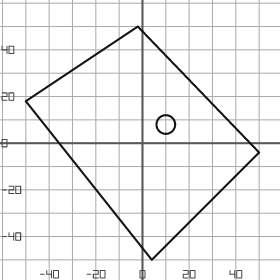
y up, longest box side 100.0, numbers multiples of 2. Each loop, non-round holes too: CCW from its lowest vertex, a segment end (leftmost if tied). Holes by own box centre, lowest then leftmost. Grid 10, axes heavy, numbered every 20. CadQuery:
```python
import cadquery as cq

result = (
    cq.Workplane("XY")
    .moveTo(4.0, -50.0)
    .lineTo(50.0, -4.0)
    .lineTo(-2.0, 50.0)
    .lineTo(-50.0, 18.0)
    .close()
    .moveTo(10.0, 8.0)
    .circle(4.0)
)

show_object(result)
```